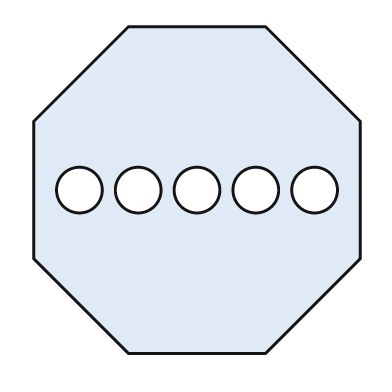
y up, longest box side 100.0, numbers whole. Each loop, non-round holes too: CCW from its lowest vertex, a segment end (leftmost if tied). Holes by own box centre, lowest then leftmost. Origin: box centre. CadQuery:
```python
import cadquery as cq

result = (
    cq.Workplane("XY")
    .moveTo(-21.0, -50.0)
    .lineTo(21.0, -50.0)
    .lineTo(50.0, -21.0)
    .lineTo(50.0, 21.0)
    .lineTo(21.0, 50.0)
    .lineTo(-21.0, 50.0)
    .lineTo(-50.0, 21.0)
    .lineTo(-50.0, -21.0)
    .close()
    .moveTo(-36.0, 0.0)
    .circle(7.0)
    .moveTo(-18.0, 0.0)
    .circle(7.0)
    .moveTo(0.0, 0.0)
    .circle(7.0)
    .moveTo(18.0, 0.0)
    .circle(7.0)
    .moveTo(36.0, 0.0)
    .circle(7.0)
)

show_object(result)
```